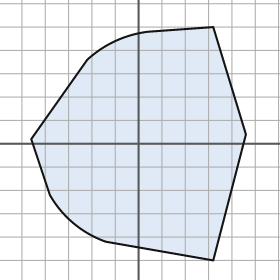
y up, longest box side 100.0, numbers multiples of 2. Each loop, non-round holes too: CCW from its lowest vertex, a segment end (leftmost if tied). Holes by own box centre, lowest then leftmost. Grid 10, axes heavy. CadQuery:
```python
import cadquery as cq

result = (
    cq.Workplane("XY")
    .moveTo(32.0, -50.0)
    .lineTo(46.0, 4.0)
    .lineTo(32.0, 50.0)
    .lineTo(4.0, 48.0)
    .threePointArc((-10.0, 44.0), (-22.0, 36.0))
    .lineTo(-46.0, 2.0)
    .lineTo(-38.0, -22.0)
    .threePointArc((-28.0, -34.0), (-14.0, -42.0))
    .close()
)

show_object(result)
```